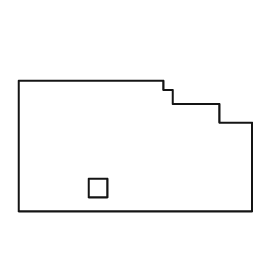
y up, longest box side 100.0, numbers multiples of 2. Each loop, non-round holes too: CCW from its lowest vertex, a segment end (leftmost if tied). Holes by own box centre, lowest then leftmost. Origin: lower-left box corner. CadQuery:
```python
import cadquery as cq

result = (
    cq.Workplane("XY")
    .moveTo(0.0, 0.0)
    .lineTo(100.0, 0.0)
    .lineTo(100.0, 38.0)
    .lineTo(86.0, 38.0)
    .lineTo(86.0, 46.0)
    .lineTo(66.0, 46.0)
    .lineTo(66.0, 52.0)
    .lineTo(62.0, 52.0)
    .lineTo(62.0, 56.0)
    .lineTo(0.0, 56.0)
    .close()
    .moveTo(30.0, 6.0)
    .lineTo(38.0, 6.0)
    .lineTo(38.0, 14.0)
    .lineTo(30.0, 14.0)
    .close()
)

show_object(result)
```